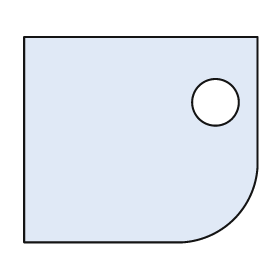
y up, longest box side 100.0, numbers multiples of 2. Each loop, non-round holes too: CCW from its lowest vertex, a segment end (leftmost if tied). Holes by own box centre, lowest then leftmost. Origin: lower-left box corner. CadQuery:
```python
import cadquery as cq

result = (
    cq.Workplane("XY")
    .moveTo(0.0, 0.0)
    .lineTo(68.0, 0.0)
    .threePointArc((90.0, 10.0), (100.0, 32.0))
    .lineTo(100.0, 88.0)
    .lineTo(0.0, 88.0)
    .close()
    .moveTo(82.0, 60.0)
    .circle(10.0)
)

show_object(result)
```